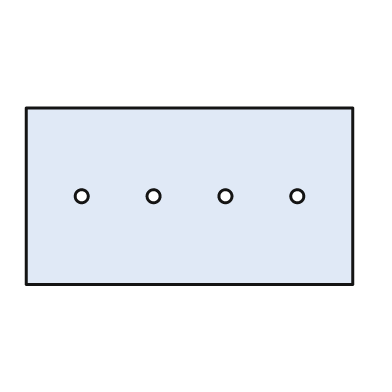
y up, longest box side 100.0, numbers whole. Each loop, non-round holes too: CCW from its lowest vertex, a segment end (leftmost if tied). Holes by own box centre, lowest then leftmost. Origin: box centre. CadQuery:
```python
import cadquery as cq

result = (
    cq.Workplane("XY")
    .moveTo(-50.0, -27.0)
    .lineTo(50.0, -27.0)
    .lineTo(50.0, 27.0)
    .lineTo(-50.0, 27.0)
    .close()
    .moveTo(-33.0, 0.0)
    .circle(2.0)
    .moveTo(-11.0, 0.0)
    .circle(2.0)
    .moveTo(11.0, 0.0)
    .circle(2.0)
    .moveTo(33.0, 0.0)
    .circle(2.0)
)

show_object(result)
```